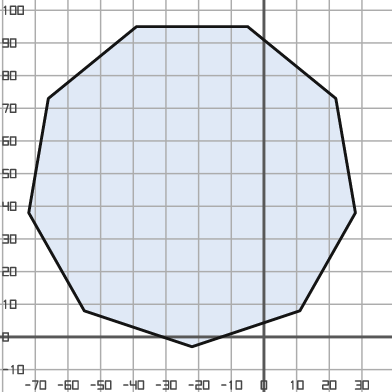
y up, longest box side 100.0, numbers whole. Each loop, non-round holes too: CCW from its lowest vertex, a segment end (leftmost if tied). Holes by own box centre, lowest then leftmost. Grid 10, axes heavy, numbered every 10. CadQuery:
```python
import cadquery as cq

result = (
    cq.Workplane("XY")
    .moveTo(-22.0, -3.0)
    .lineTo(11.0, 8.0)
    .lineTo(28.0, 38.0)
    .lineTo(22.0, 73.0)
    .lineTo(-5.0, 95.0)
    .lineTo(-39.0, 95.0)
    .lineTo(-66.0, 73.0)
    .lineTo(-72.0, 38.0)
    .lineTo(-55.0, 8.0)
    .close()
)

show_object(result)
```